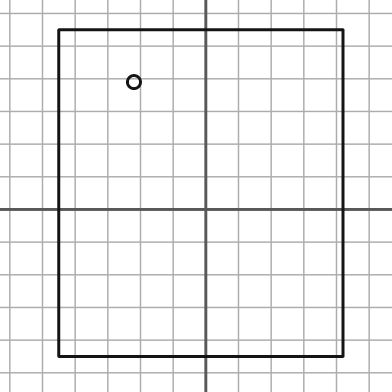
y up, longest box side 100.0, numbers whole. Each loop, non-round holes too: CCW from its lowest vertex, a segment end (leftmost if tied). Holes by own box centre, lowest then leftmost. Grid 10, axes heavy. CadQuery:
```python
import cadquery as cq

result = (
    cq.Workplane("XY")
    .moveTo(-45.0, -45.0)
    .lineTo(42.0, -45.0)
    .lineTo(42.0, 55.0)
    .lineTo(-45.0, 55.0)
    .close()
    .moveTo(-22.0, 39.0)
    .circle(2.0)
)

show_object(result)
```